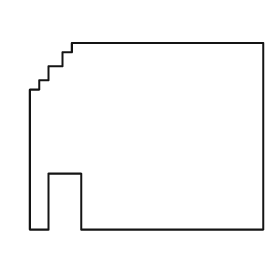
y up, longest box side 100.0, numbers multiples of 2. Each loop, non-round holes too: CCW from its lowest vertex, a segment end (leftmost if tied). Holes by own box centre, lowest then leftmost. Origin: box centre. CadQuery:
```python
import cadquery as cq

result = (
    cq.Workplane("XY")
    .moveTo(-50.0, -40.0)
    .lineTo(-42.0, -40.0)
    .lineTo(-42.0, -16.0)
    .lineTo(-28.0, -16.0)
    .lineTo(-28.0, -40.0)
    .lineTo(50.0, -40.0)
    .lineTo(50.0, 40.0)
    .lineTo(-32.0, 40.0)
    .lineTo(-32.0, 36.0)
    .lineTo(-36.0, 36.0)
    .lineTo(-36.0, 30.0)
    .lineTo(-42.0, 30.0)
    .lineTo(-42.0, 24.0)
    .lineTo(-46.0, 24.0)
    .lineTo(-46.0, 20.0)
    .lineTo(-50.0, 20.0)
    .close()
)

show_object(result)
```